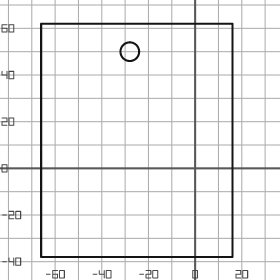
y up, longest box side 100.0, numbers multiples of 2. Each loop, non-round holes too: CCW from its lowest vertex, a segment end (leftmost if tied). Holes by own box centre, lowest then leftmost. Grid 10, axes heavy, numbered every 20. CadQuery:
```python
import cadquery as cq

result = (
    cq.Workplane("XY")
    .moveTo(-66.0, -38.0)
    .lineTo(16.0, -38.0)
    .lineTo(16.0, 62.0)
    .lineTo(-66.0, 62.0)
    .close()
    .moveTo(-28.0, 50.0)
    .circle(4.0)
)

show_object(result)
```